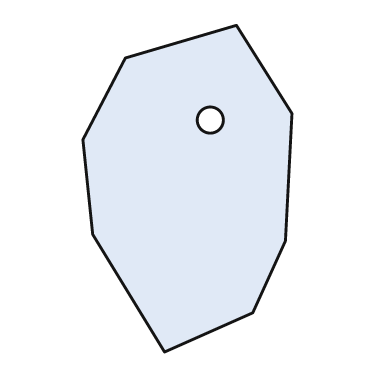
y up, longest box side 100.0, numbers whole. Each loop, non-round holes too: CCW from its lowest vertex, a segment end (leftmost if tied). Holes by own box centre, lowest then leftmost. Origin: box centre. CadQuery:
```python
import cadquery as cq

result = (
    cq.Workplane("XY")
    .moveTo(-7.0, -50.0)
    .lineTo(20.0, -38.0)
    .lineTo(30.0, -16.0)
    .lineTo(32.0, 23.0)
    .lineTo(15.0, 50.0)
    .lineTo(-19.0, 40.0)
    .lineTo(-32.0, 15.0)
    .lineTo(-29.0, -14.0)
    .close()
    .moveTo(7.0, 21.0)
    .circle(4.0)
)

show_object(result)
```